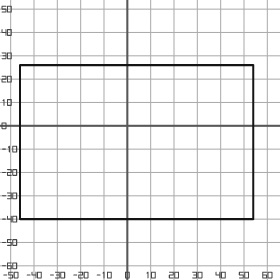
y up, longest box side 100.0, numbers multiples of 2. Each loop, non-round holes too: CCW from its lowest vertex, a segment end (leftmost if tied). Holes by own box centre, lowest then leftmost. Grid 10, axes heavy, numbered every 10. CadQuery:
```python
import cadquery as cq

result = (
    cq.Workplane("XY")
    .moveTo(-46.0, -40.0)
    .lineTo(54.0, -40.0)
    .lineTo(54.0, 26.0)
    .lineTo(-46.0, 26.0)
    .close()
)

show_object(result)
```